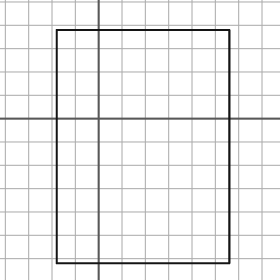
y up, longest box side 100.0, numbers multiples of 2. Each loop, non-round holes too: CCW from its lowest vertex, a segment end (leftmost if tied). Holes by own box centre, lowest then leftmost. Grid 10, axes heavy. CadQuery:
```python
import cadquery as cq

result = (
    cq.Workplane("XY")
    .moveTo(-18.0, -62.0)
    .lineTo(56.0, -62.0)
    .lineTo(56.0, 38.0)
    .lineTo(-18.0, 38.0)
    .close()
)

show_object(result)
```